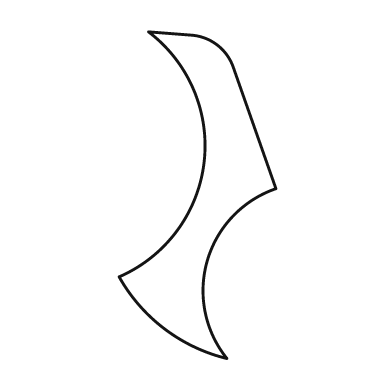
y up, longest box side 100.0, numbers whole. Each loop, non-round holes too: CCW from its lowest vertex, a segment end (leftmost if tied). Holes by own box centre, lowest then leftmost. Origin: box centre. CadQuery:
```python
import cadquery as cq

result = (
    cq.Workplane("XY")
    .moveTo(9.0, -50.0)
    .threePointArc((3.0, -20.0), (24.0, 2.0))
    .lineTo(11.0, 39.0)
    .threePointArc((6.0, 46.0), (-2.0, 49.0))
    .lineTo(-15.0, 50.0)
    .threePointArc((2.0, 10.0), (-24.0, -25.0))
    .threePointArc((-10.0, -41.0), (9.0, -50.0))
    .close()
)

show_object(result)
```